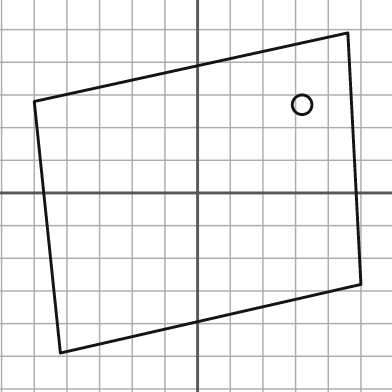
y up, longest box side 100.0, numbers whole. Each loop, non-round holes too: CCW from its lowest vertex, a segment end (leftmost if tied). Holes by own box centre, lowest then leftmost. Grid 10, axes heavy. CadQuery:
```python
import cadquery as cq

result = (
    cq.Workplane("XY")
    .moveTo(-42.0, -49.0)
    .lineTo(50.0, -28.0)
    .lineTo(46.0, 49.0)
    .lineTo(-50.0, 28.0)
    .close()
    .moveTo(32.0, 27.0)
    .circle(3.0)
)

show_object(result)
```